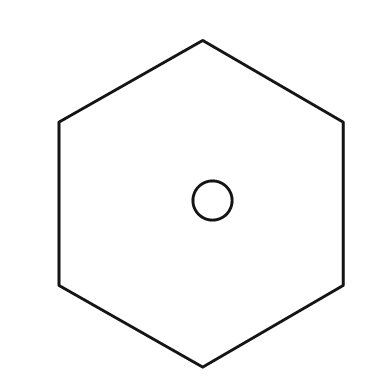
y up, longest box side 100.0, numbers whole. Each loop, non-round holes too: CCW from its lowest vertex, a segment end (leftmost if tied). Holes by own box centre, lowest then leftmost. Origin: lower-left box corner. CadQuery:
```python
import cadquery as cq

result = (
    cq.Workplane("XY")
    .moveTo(44.0, 0.0)
    .lineTo(87.0, 25.0)
    .lineTo(87.0, 75.0)
    .lineTo(44.0, 100.0)
    .lineTo(0.0, 75.0)
    .lineTo(0.0, 25.0)
    .close()
    .moveTo(47.0, 51.0)
    .circle(6.0)
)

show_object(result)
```